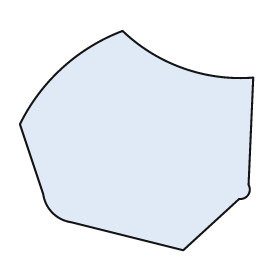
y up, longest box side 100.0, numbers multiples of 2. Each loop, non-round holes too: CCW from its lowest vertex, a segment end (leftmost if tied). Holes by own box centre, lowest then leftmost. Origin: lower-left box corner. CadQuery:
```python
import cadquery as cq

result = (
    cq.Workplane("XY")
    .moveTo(70.0, 0.0)
    .lineTo(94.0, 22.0)
    .threePointArc((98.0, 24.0), (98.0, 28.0))
    .lineTo(100.0, 74.0)
    .threePointArc((70.0, 78.0), (44.0, 94.0))
    .threePointArc((18.0, 78.0), (0.0, 54.0))
    .lineTo(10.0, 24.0)
    .threePointArc((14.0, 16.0), (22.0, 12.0))
    .close()
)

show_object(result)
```